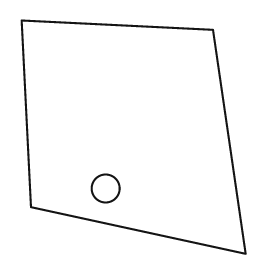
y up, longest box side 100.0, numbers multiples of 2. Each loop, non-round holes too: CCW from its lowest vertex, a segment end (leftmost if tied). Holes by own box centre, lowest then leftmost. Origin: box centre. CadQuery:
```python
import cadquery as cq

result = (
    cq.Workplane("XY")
    .moveTo(48.0, -50.0)
    .lineTo(34.0, 46.0)
    .lineTo(-48.0, 50.0)
    .lineTo(-44.0, -30.0)
    .close()
    .moveTo(-12.0, -22.0)
    .circle(6.0)
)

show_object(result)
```